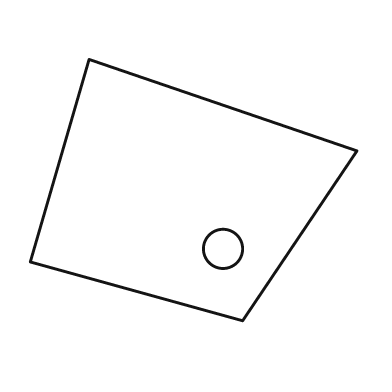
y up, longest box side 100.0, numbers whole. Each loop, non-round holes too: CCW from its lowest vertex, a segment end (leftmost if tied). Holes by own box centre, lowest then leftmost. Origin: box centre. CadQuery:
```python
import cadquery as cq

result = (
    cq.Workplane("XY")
    .moveTo(15.0, -40.0)
    .lineTo(50.0, 12.0)
    .lineTo(-32.0, 40.0)
    .lineTo(-50.0, -22.0)
    .close()
    .moveTo(9.0, -18.0)
    .circle(6.0)
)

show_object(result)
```